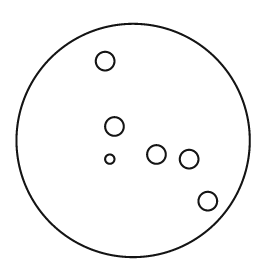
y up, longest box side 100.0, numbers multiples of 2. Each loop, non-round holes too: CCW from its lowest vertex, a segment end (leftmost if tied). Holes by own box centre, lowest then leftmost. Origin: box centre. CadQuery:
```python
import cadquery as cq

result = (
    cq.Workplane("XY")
    .moveTo(0.0, 0.0)
    .circle(50.0)
    .moveTo(32.0, -26.0)
    .circle(4.0)
    .moveTo(-10.0, -8.0)
    .circle(2.0)
    .moveTo(24.0, -8.0)
    .circle(4.0)
    .moveTo(10.0, -6.0)
    .circle(4.0)
    .moveTo(-8.0, 6.0)
    .circle(4.0)
    .moveTo(-12.0, 34.0)
    .circle(4.0)
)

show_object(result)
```